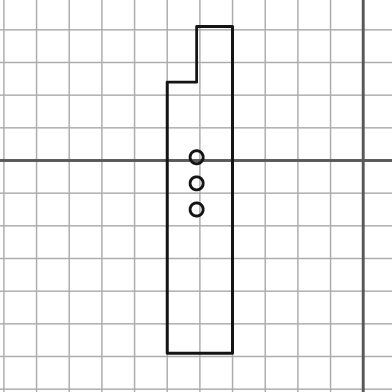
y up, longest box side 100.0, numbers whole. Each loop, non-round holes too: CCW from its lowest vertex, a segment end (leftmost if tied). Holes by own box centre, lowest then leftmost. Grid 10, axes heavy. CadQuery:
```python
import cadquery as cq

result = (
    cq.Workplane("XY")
    .moveTo(-60.0, -59.0)
    .lineTo(-40.0, -59.0)
    .lineTo(-40.0, 41.0)
    .lineTo(-51.0, 41.0)
    .lineTo(-51.0, 24.0)
    .lineTo(-60.0, 24.0)
    .close()
    .moveTo(-51.0, -15.0)
    .circle(2.0)
    .moveTo(-51.0, -7.0)
    .circle(2.0)
    .moveTo(-51.0, 1.0)
    .circle(2.0)
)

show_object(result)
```